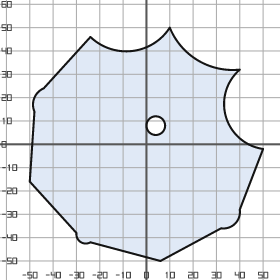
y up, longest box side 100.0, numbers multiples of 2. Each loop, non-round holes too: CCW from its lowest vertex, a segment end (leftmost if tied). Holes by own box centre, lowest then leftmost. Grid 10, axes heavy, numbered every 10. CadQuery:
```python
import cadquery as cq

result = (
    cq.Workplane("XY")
    .moveTo(6.0, -50.0)
    .lineTo(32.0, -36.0)
    .threePointArc((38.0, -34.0), (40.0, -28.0))
    .lineTo(50.0, -2.0)
    .threePointArc((34.0, 12.0), (40.0, 32.0))
    .threePointArc((22.0, 36.0), (10.0, 50.0))
    .threePointArc((-6.0, 40.0), (-24.0, 46.0))
    .lineTo(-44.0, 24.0)
    .threePointArc((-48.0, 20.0), (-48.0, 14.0))
    .lineTo(-50.0, -16.0)
    .lineTo(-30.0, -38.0)
    .threePointArc((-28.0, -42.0), (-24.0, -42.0))
    .close()
    .moveTo(4.0, 8.0)
    .circle(4.0)
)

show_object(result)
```